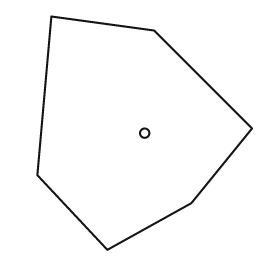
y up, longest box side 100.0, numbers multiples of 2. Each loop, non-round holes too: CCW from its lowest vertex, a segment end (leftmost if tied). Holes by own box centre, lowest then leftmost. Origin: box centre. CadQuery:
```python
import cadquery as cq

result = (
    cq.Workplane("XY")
    .moveTo(-16.0, -50.0)
    .lineTo(20.0, -30.0)
    .lineTo(46.0, 2.0)
    .lineTo(4.0, 44.0)
    .lineTo(-40.0, 50.0)
    .lineTo(-46.0, -18.0)
    .close()
    .moveTo(0.0, 0.0)
    .circle(2.0)
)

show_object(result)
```